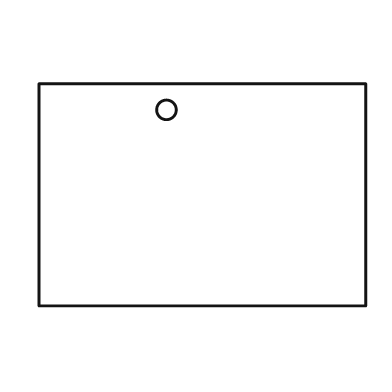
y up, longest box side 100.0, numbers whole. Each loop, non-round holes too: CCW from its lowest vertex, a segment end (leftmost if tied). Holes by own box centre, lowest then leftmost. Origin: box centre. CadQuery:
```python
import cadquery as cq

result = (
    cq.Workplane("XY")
    .moveTo(-50.0, -34.0)
    .lineTo(50.0, -34.0)
    .lineTo(50.0, 34.0)
    .lineTo(-50.0, 34.0)
    .close()
    .moveTo(-11.0, 26.0)
    .circle(3.0)
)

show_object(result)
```